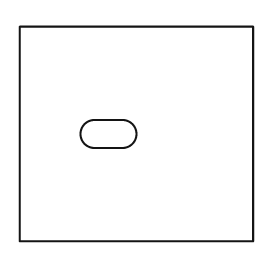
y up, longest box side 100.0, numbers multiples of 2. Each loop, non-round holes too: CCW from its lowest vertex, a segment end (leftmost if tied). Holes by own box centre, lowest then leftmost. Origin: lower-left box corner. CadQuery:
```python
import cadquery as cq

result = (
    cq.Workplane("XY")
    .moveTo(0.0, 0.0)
    .lineTo(100.0, 0.0)
    .lineTo(100.0, 92.0)
    .lineTo(0.0, 92.0)
    .close()
    .moveTo(32.0, 40.0)
    .lineTo(44.0, 40.0)
    .threePointArc((50.0, 46.0), (44.0, 52.0))
    .lineTo(32.0, 52.0)
    .threePointArc((26.0, 46.0), (32.0, 40.0))
    .close()
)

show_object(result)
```